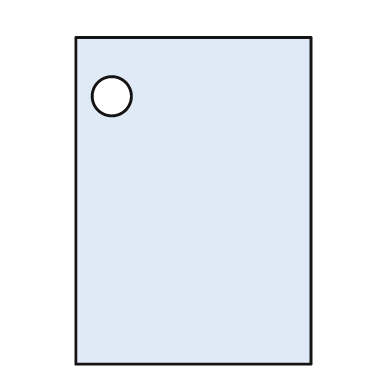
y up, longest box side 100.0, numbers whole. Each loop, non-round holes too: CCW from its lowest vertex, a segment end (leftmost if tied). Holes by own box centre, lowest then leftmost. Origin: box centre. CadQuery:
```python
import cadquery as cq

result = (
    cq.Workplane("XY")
    .moveTo(-36.0, -50.0)
    .lineTo(36.0, -50.0)
    .lineTo(36.0, 50.0)
    .lineTo(-36.0, 50.0)
    .close()
    .moveTo(-25.0, 32.0)
    .circle(6.0)
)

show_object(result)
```